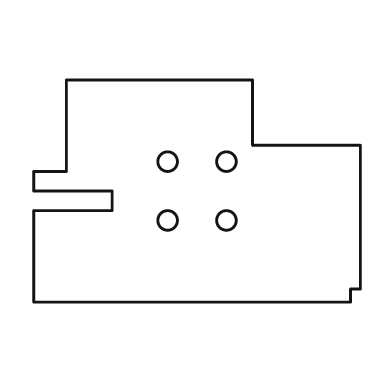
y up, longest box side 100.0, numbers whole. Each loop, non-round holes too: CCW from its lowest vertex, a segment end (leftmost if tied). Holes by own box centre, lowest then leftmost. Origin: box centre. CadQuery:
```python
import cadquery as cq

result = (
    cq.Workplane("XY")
    .moveTo(-50.0, -34.0)
    .lineTo(47.0, -34.0)
    .lineTo(47.0, -30.0)
    .lineTo(50.0, -30.0)
    .lineTo(50.0, 14.0)
    .lineTo(17.0, 14.0)
    .lineTo(17.0, 34.0)
    .lineTo(-40.0, 34.0)
    .lineTo(-40.0, 6.0)
    .lineTo(-50.0, 6.0)
    .lineTo(-50.0, 0.0)
    .lineTo(-26.0, 0.0)
    .lineTo(-26.0, -6.0)
    .lineTo(-50.0, -6.0)
    .close()
    .moveTo(-9.0, -9.0)
    .circle(3.0)
    .moveTo(9.0, -9.0)
    .circle(3.0)
    .moveTo(-9.0, 9.0)
    .circle(3.0)
    .moveTo(9.0, 9.0)
    .circle(3.0)
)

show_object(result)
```